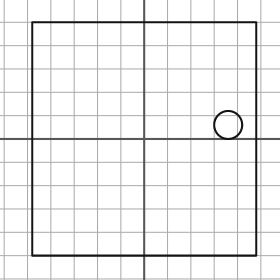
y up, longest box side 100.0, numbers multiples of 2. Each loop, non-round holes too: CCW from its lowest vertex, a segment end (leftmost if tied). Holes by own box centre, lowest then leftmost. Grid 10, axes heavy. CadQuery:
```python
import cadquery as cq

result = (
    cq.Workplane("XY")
    .moveTo(-48.0, -50.0)
    .lineTo(48.0, -50.0)
    .lineTo(48.0, 50.0)
    .lineTo(-48.0, 50.0)
    .close()
    .moveTo(36.0, 6.0)
    .circle(6.0)
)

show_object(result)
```